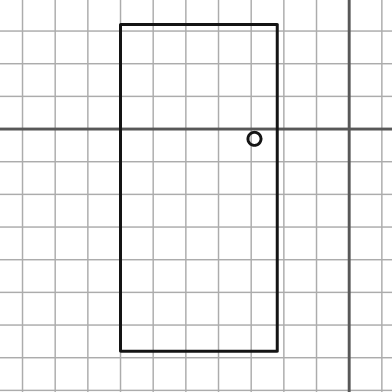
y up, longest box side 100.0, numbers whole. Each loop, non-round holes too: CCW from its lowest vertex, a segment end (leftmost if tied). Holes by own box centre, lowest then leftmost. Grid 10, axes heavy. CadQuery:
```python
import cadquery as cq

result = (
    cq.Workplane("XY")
    .moveTo(-70.0, -68.0)
    .lineTo(-22.0, -68.0)
    .lineTo(-22.0, 32.0)
    .lineTo(-70.0, 32.0)
    .close()
    .moveTo(-29.0, -3.0)
    .circle(2.0)
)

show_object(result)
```